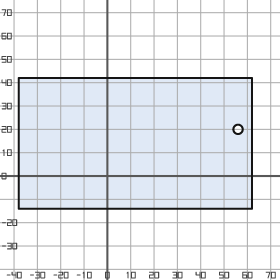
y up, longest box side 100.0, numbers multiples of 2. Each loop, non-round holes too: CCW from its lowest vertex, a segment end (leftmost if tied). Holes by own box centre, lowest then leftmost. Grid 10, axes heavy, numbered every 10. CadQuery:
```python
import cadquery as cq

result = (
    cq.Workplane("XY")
    .moveTo(-38.0, -14.0)
    .lineTo(62.0, -14.0)
    .lineTo(62.0, 42.0)
    .lineTo(-38.0, 42.0)
    .close()
    .moveTo(56.0, 20.0)
    .circle(2.0)
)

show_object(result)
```